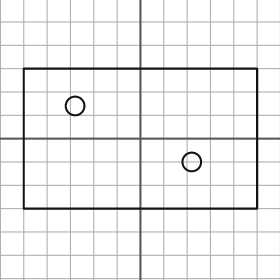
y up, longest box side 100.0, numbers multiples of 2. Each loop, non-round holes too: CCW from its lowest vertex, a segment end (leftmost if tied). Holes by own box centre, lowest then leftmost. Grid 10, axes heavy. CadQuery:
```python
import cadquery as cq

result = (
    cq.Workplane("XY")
    .moveTo(-50.0, -30.0)
    .lineTo(50.0, -30.0)
    .lineTo(50.0, 30.0)
    .lineTo(-50.0, 30.0)
    .close()
    .moveTo(22.0, -10.0)
    .circle(4.0)
    .moveTo(-28.0, 14.0)
    .circle(4.0)
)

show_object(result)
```